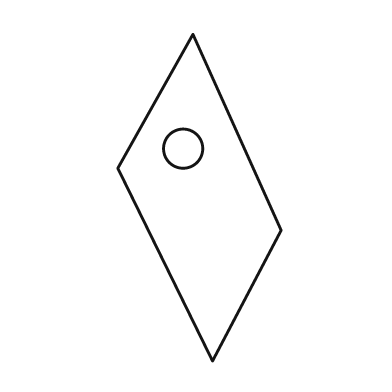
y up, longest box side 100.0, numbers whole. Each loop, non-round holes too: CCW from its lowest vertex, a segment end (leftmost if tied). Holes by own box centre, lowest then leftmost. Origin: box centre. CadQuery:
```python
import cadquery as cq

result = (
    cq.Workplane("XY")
    .moveTo(4.0, -50.0)
    .lineTo(25.0, -10.0)
    .lineTo(-2.0, 50.0)
    .lineTo(-25.0, 9.0)
    .close()
    .moveTo(-5.0, 15.0)
    .circle(6.0)
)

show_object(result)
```